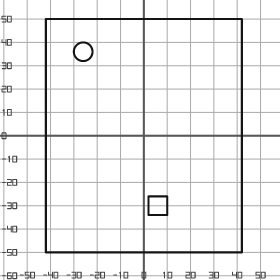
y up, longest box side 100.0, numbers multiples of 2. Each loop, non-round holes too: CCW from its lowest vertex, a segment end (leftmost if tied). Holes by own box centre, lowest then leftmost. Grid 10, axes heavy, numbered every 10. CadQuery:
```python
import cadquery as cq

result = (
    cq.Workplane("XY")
    .moveTo(-42.0, -50.0)
    .lineTo(42.0, -50.0)
    .lineTo(42.0, 50.0)
    .lineTo(-42.0, 50.0)
    .close()
    .moveTo(2.0, -34.0)
    .lineTo(10.0, -34.0)
    .lineTo(10.0, -26.0)
    .lineTo(2.0, -26.0)
    .close()
    .moveTo(-26.0, 36.0)
    .circle(4.0)
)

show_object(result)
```